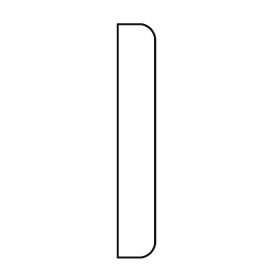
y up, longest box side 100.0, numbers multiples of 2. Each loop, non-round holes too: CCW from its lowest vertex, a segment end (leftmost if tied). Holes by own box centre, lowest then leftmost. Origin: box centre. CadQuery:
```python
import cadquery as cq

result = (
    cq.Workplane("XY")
    .moveTo(-8.0, -50.0)
    .lineTo(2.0, -50.0)
    .threePointArc((6.0, -48.0), (8.0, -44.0))
    .lineTo(8.0, 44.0)
    .threePointArc((6.0, 48.0), (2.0, 50.0))
    .lineTo(-8.0, 50.0)
    .close()
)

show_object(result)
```